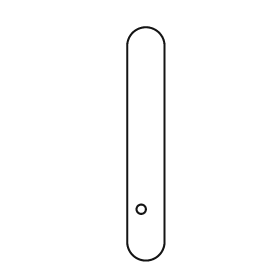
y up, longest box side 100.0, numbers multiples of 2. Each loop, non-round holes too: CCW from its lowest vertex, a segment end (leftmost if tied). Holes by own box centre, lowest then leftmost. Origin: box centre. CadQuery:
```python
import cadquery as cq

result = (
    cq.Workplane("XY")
    .moveTo(-8.0, -42.0)
    .threePointArc((0.0, -50.0), (8.0, -42.0))
    .lineTo(8.0, 42.0)
    .threePointArc((0.0, 50.0), (-8.0, 42.0))
    .close()
    .moveTo(-2.0, -28.0)
    .circle(2.0)
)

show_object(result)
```